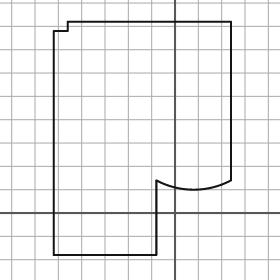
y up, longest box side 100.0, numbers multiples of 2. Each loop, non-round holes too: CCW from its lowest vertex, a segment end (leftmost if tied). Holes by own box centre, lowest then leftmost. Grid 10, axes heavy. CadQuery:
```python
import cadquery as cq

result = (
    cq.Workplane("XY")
    .moveTo(-52.0, -18.0)
    .lineTo(-8.0, -18.0)
    .lineTo(-8.0, 14.0)
    .threePointArc((8.0, 10.0), (24.0, 14.0))
    .lineTo(24.0, 82.0)
    .lineTo(-46.0, 82.0)
    .lineTo(-46.0, 78.0)
    .lineTo(-52.0, 78.0)
    .close()
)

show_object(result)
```